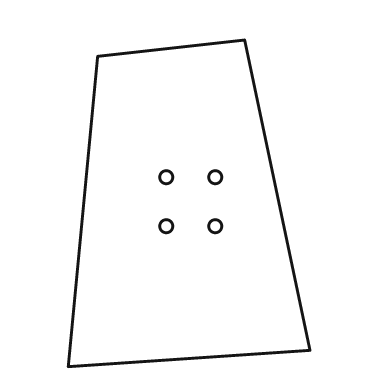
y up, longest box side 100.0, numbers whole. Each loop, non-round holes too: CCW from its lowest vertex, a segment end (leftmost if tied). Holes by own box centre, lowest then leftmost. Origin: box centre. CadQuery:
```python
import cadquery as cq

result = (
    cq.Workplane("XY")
    .moveTo(-37.0, -50.0)
    .lineTo(37.0, -45.0)
    .lineTo(17.0, 50.0)
    .lineTo(-28.0, 45.0)
    .close()
    .moveTo(-7.0, -7.0)
    .circle(2.0)
    .moveTo(8.0, -7.0)
    .circle(2.0)
    .moveTo(-7.0, 8.0)
    .circle(2.0)
    .moveTo(8.0, 8.0)
    .circle(2.0)
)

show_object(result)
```